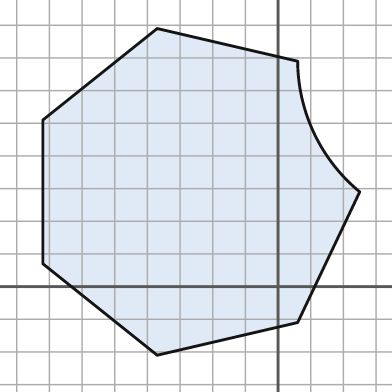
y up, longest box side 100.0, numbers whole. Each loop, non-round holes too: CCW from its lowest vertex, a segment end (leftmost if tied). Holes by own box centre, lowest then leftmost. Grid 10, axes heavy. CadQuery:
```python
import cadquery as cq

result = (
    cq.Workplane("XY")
    .moveTo(-37.0, -21.0)
    .lineTo(6.0, -11.0)
    .lineTo(25.0, 29.0)
    .threePointArc((11.0, 47.0), (6.0, 69.0))
    .lineTo(-37.0, 79.0)
    .lineTo(-72.0, 51.0)
    .lineTo(-72.0, 7.0)
    .close()
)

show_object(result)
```